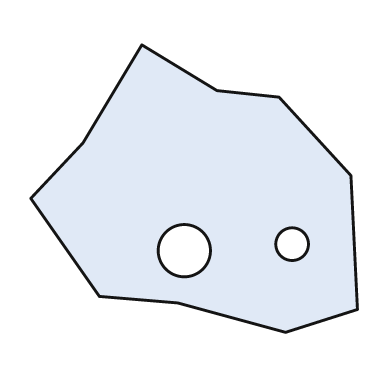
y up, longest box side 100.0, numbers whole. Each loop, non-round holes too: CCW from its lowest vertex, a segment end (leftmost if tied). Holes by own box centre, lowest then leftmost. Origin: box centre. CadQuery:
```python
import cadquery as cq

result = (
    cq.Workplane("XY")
    .moveTo(28.0, -44.0)
    .lineTo(50.0, -37.0)
    .lineTo(48.0, 4.0)
    .lineTo(26.0, 28.0)
    .lineTo(7.0, 30.0)
    .lineTo(-16.0, 44.0)
    .lineTo(-34.0, 14.0)
    .lineTo(-50.0, -3.0)
    .lineTo(-29.0, -33.0)
    .lineTo(-5.0, -35.0)
    .close()
    .moveTo(-3.0, -19.0)
    .circle(8.0)
    .moveTo(30.0, -17.0)
    .circle(5.0)
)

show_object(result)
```